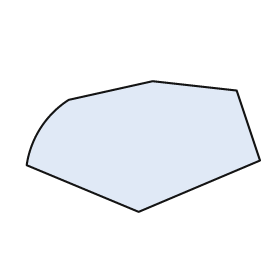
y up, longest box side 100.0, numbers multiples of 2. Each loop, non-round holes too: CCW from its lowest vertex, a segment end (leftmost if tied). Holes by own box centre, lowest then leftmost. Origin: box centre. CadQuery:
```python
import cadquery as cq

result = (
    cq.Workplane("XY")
    .moveTo(-2.0, -28.0)
    .lineTo(50.0, -6.0)
    .lineTo(40.0, 24.0)
    .lineTo(4.0, 28.0)
    .lineTo(-32.0, 20.0)
    .threePointArc((-44.0, 8.0), (-50.0, -8.0))
    .close()
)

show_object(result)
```